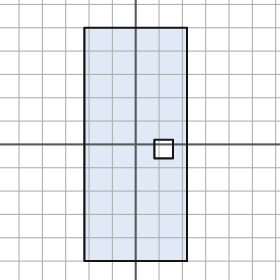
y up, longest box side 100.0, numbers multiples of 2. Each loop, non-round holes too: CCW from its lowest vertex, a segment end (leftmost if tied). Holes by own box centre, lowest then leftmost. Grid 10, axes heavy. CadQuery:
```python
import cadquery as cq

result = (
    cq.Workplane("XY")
    .moveTo(-22.0, -50.0)
    .lineTo(22.0, -50.0)
    .lineTo(22.0, 50.0)
    .lineTo(-22.0, 50.0)
    .close()
    .moveTo(8.0, -6.0)
    .lineTo(16.0, -6.0)
    .lineTo(16.0, 2.0)
    .lineTo(8.0, 2.0)
    .close()
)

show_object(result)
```